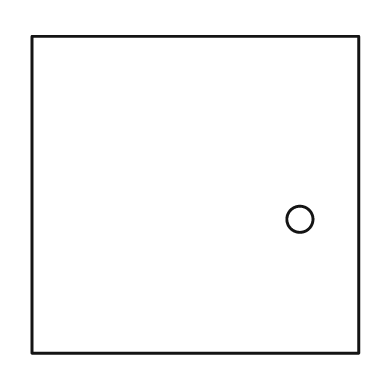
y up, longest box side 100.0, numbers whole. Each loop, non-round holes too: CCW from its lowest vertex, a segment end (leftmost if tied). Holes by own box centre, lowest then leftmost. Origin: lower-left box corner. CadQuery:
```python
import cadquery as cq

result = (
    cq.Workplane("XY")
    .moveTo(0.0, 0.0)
    .lineTo(100.0, 0.0)
    .lineTo(100.0, 97.0)
    .lineTo(0.0, 97.0)
    .close()
    .moveTo(82.0, 41.0)
    .circle(4.0)
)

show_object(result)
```